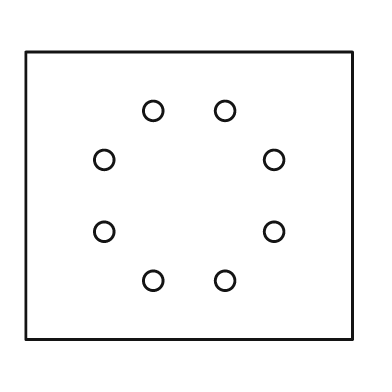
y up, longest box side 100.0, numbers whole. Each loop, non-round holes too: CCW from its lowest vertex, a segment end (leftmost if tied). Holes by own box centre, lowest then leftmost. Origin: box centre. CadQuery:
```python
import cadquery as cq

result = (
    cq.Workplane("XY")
    .moveTo(-50.0, -44.0)
    .lineTo(50.0, -44.0)
    .lineTo(50.0, 44.0)
    .lineTo(-50.0, 44.0)
    .close()
    .moveTo(-11.0, -26.0)
    .circle(3.0)
    .moveTo(11.0, -26.0)
    .circle(3.0)
    .moveTo(-26.0, -11.0)
    .circle(3.0)
    .moveTo(26.0, -11.0)
    .circle(3.0)
    .moveTo(-26.0, 11.0)
    .circle(3.0)
    .moveTo(26.0, 11.0)
    .circle(3.0)
    .moveTo(-11.0, 26.0)
    .circle(3.0)
    .moveTo(11.0, 26.0)
    .circle(3.0)
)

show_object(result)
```